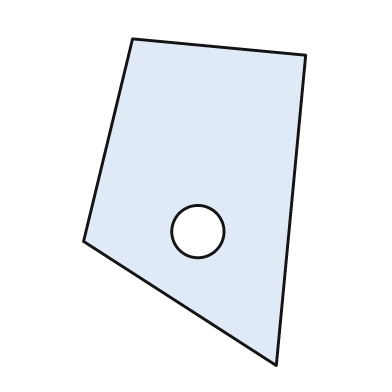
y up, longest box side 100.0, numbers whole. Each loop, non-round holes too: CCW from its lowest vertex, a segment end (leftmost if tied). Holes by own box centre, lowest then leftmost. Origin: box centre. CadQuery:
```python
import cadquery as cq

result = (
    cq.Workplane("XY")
    .moveTo(25.0, -50.0)
    .lineTo(34.0, 45.0)
    .lineTo(-19.0, 50.0)
    .lineTo(-34.0, -12.0)
    .close()
    .moveTo(1.0, -9.0)
    .circle(8.0)
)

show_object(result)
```